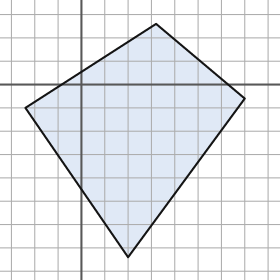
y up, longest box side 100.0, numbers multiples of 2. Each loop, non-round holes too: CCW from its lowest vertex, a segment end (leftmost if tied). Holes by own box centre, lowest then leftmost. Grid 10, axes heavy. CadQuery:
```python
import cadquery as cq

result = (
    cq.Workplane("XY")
    .moveTo(20.0, -74.0)
    .lineTo(70.0, -6.0)
    .lineTo(32.0, 26.0)
    .lineTo(-24.0, -10.0)
    .close()
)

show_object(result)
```